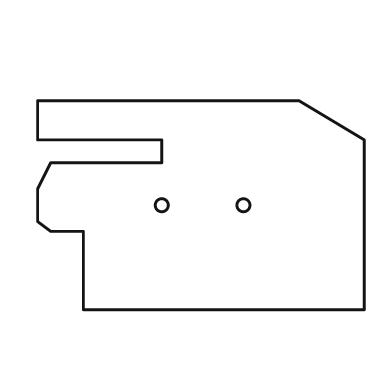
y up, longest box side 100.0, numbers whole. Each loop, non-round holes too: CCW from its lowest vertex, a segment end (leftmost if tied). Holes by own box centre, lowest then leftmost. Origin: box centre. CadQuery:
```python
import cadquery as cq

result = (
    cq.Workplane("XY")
    .moveTo(-36.0, -32.0)
    .lineTo(50.0, -32.0)
    .lineTo(50.0, 20.0)
    .lineTo(30.0, 32.0)
    .lineTo(-50.0, 32.0)
    .lineTo(-50.0, 20.0)
    .lineTo(-12.0, 20.0)
    .lineTo(-12.0, 13.0)
    .lineTo(-46.0, 13.0)
    .lineTo(-50.0, 5.0)
    .lineTo(-50.0, -5.0)
    .lineTo(-46.0, -8.0)
    .lineTo(-36.0, -8.0)
    .close()
    .moveTo(-12.0, 0.0)
    .circle(2.0)
    .moveTo(13.0, 0.0)
    .circle(2.0)
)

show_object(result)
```